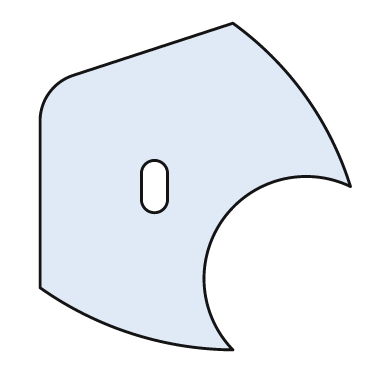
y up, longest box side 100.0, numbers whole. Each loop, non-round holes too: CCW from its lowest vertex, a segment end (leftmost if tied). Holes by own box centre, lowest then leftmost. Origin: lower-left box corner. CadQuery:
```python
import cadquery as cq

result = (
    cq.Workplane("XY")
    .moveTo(59.0, 0.0)
    .threePointArc((56.0, 40.0), (95.0, 50.0))
    .threePointArc((81.0, 78.0), (59.0, 100.0))
    .lineTo(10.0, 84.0)
    .threePointArc((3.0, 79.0), (0.0, 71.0))
    .lineTo(0.0, 19.0)
    .threePointArc((28.0, 5.0), (59.0, 0.0))
    .close()
    .moveTo(31.0, 46.0)
    .threePointArc((35.0, 42.0), (39.0, 46.0))
    .lineTo(39.0, 54.0)
    .threePointArc((35.0, 58.0), (31.0, 54.0))
    .close()
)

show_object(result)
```